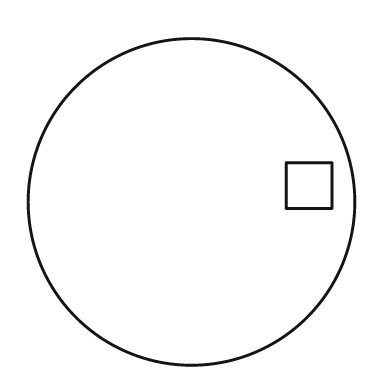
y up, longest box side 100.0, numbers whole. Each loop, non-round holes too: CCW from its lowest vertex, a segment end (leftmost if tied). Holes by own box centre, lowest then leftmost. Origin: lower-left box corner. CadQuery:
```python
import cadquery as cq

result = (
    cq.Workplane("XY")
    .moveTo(50.0, 50.0)
    .circle(50.0)
    .moveTo(79.0, 48.0)
    .lineTo(93.0, 48.0)
    .lineTo(93.0, 62.0)
    .lineTo(79.0, 62.0)
    .close()
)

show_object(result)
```